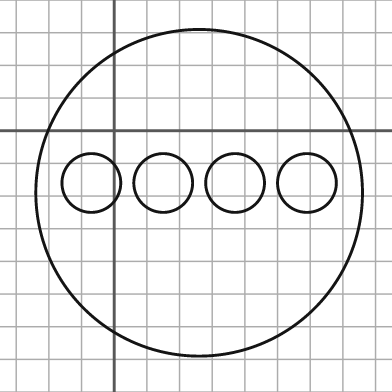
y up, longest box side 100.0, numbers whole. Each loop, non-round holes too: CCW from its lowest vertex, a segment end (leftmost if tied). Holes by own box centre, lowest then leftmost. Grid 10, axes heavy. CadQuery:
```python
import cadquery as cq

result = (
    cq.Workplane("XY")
    .moveTo(26.0, -19.0)
    .circle(50.0)
    .moveTo(-7.0, -16.0)
    .circle(9.0)
    .moveTo(15.0, -16.0)
    .circle(9.0)
    .moveTo(37.0, -16.0)
    .circle(9.0)
    .moveTo(59.0, -16.0)
    .circle(9.0)
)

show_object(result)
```